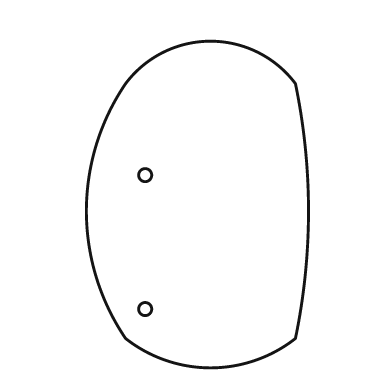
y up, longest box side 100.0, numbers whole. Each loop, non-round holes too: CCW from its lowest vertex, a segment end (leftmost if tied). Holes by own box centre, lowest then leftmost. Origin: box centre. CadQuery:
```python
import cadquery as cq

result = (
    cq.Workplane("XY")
    .moveTo(-22.0, -41.0)
    .threePointArc((4.0, -50.0), (30.0, -41.0))
    .threePointArc((34.0, -2.0), (30.0, 37.0))
    .threePointArc((4.0, 50.0), (-22.0, 37.0))
    .threePointArc((-34.0, -2.0), (-22.0, -41.0))
    .close()
    .moveTo(-16.0, -32.0)
    .circle(2.0)
    .moveTo(-16.0, 9.0)
    .circle(2.0)
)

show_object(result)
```